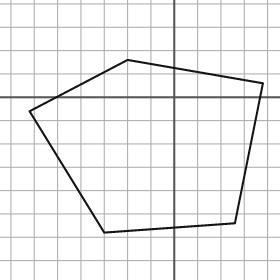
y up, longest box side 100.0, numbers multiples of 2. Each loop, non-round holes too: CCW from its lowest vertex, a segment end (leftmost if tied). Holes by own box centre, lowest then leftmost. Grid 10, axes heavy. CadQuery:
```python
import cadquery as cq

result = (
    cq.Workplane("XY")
    .moveTo(-30.0, -58.0)
    .lineTo(26.0, -54.0)
    .lineTo(38.0, 6.0)
    .lineTo(-20.0, 16.0)
    .lineTo(-62.0, -6.0)
    .close()
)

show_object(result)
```